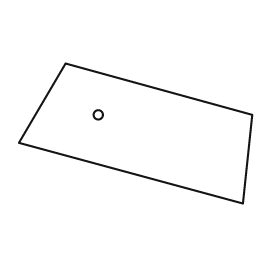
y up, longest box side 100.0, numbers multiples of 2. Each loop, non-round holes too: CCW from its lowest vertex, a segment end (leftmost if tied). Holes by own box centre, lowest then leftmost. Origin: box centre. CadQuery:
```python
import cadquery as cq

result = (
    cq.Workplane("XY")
    .moveTo(46.0, -30.0)
    .lineTo(50.0, 8.0)
    .lineTo(-30.0, 30.0)
    .lineTo(-50.0, -4.0)
    .close()
    .moveTo(-16.0, 8.0)
    .circle(2.0)
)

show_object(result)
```